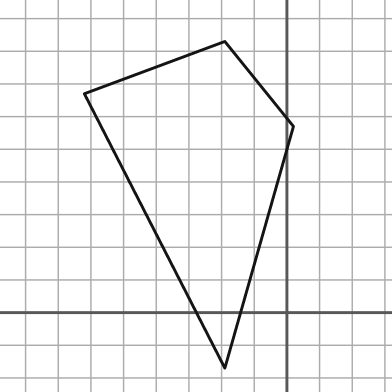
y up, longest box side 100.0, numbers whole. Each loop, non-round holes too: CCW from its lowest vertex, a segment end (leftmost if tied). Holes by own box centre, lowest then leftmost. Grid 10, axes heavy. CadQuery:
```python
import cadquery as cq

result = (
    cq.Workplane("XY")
    .moveTo(-19.0, -17.0)
    .lineTo(2.0, 57.0)
    .lineTo(-19.0, 83.0)
    .lineTo(-62.0, 67.0)
    .close()
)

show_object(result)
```